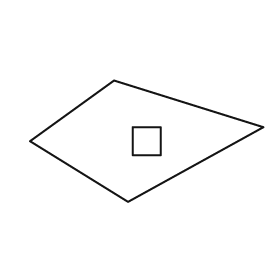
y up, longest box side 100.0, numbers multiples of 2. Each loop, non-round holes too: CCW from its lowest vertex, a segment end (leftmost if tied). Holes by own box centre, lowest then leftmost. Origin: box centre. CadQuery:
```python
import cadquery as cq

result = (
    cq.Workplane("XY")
    .moveTo(-8.0, -26.0)
    .lineTo(50.0, 6.0)
    .lineTo(-14.0, 26.0)
    .lineTo(-50.0, 0.0)
    .close()
    .moveTo(-6.0, -6.0)
    .lineTo(6.0, -6.0)
    .lineTo(6.0, 6.0)
    .lineTo(-6.0, 6.0)
    .close()
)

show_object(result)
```